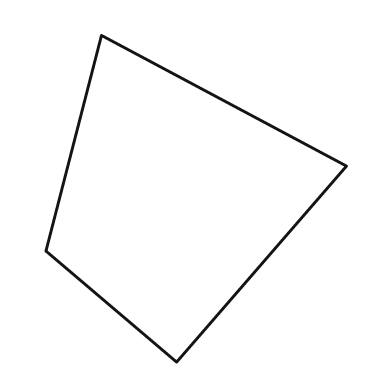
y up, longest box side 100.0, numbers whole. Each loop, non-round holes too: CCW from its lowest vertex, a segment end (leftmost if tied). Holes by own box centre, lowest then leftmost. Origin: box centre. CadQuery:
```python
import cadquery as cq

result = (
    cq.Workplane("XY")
    .moveTo(-6.0, -50.0)
    .lineTo(46.0, 10.0)
    .lineTo(-29.0, 50.0)
    .lineTo(-46.0, -16.0)
    .close()
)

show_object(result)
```